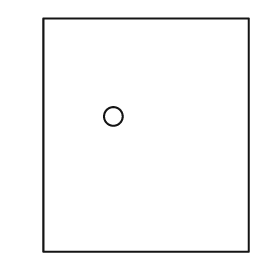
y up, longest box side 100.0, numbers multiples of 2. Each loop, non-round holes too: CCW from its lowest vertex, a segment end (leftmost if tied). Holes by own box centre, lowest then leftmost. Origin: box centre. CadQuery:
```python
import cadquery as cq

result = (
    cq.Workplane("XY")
    .moveTo(-44.0, -50.0)
    .lineTo(44.0, -50.0)
    .lineTo(44.0, 50.0)
    .lineTo(-44.0, 50.0)
    .close()
    .moveTo(-14.0, 8.0)
    .circle(4.0)
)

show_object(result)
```